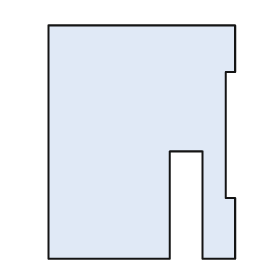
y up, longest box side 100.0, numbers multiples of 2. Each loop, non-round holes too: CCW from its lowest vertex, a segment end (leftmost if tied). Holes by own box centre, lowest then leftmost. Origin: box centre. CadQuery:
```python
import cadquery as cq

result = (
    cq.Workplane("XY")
    .moveTo(-40.0, -50.0)
    .lineTo(12.0, -50.0)
    .lineTo(12.0, -4.0)
    .lineTo(26.0, -4.0)
    .lineTo(26.0, -50.0)
    .lineTo(40.0, -50.0)
    .lineTo(40.0, -24.0)
    .lineTo(36.0, -24.0)
    .lineTo(36.0, 30.0)
    .lineTo(40.0, 30.0)
    .lineTo(40.0, 50.0)
    .lineTo(-40.0, 50.0)
    .close()
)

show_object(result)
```